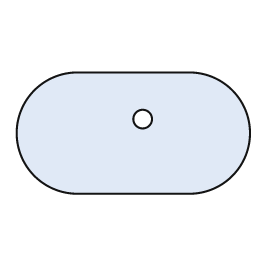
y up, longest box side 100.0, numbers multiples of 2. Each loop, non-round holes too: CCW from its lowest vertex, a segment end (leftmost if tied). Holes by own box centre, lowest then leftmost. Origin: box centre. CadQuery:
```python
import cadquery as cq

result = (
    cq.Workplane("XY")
    .moveTo(-24.0, -26.0)
    .lineTo(24.0, -26.0)
    .threePointArc((50.0, 0.0), (24.0, 26.0))
    .lineTo(-24.0, 26.0)
    .threePointArc((-50.0, 0.0), (-24.0, -26.0))
    .close()
    .moveTo(4.0, 6.0)
    .circle(4.0)
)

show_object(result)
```